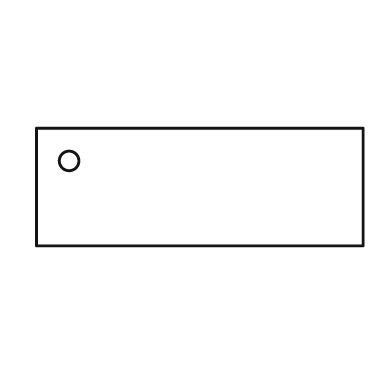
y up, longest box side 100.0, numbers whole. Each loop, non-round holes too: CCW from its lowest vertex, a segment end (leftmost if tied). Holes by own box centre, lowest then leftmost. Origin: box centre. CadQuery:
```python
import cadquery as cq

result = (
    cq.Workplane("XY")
    .moveTo(-50.0, -18.0)
    .lineTo(50.0, -18.0)
    .lineTo(50.0, 18.0)
    .lineTo(-50.0, 18.0)
    .close()
    .moveTo(-40.0, 8.0)
    .circle(3.0)
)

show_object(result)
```